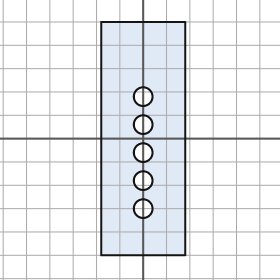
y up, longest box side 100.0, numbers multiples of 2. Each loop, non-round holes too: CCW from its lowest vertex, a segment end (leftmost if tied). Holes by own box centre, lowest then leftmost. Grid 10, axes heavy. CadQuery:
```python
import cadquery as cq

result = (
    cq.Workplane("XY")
    .moveTo(-18.0, -50.0)
    .lineTo(18.0, -50.0)
    .lineTo(18.0, 50.0)
    .lineTo(-18.0, 50.0)
    .close()
    .moveTo(0.0, -30.0)
    .circle(4.0)
    .moveTo(0.0, -18.0)
    .circle(4.0)
    .moveTo(0.0, -6.0)
    .circle(4.0)
    .moveTo(0.0, 6.0)
    .circle(4.0)
    .moveTo(0.0, 18.0)
    .circle(4.0)
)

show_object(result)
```